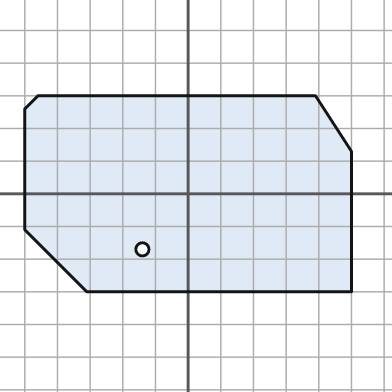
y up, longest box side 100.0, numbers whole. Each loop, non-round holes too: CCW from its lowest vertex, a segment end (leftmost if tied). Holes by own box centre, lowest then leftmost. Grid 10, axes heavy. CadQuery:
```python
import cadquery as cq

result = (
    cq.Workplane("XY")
    .moveTo(-31.0, -30.0)
    .lineTo(50.0, -30.0)
    .lineTo(50.0, 13.0)
    .lineTo(39.0, 30.0)
    .lineTo(-46.0, 30.0)
    .lineTo(-50.0, 26.0)
    .lineTo(-50.0, -11.0)
    .close()
    .moveTo(-14.0, -17.0)
    .circle(2.0)
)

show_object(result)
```